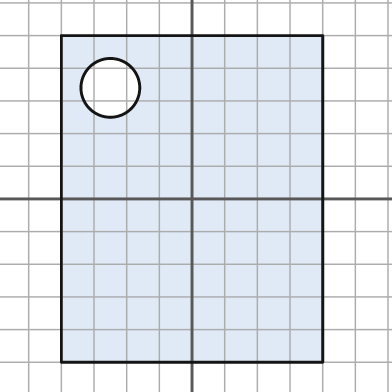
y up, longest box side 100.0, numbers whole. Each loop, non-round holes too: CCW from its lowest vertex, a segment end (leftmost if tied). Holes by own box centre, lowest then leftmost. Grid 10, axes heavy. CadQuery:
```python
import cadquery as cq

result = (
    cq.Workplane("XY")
    .moveTo(-40.0, -50.0)
    .lineTo(40.0, -50.0)
    .lineTo(40.0, 50.0)
    .lineTo(-40.0, 50.0)
    .close()
    .moveTo(-25.0, 34.0)
    .circle(9.0)
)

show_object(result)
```